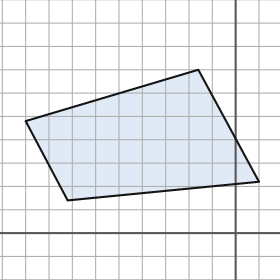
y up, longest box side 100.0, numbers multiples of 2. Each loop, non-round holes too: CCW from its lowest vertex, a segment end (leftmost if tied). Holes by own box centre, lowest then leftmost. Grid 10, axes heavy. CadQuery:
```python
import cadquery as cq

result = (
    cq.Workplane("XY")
    .moveTo(-72.0, 14.0)
    .lineTo(10.0, 22.0)
    .lineTo(-16.0, 70.0)
    .lineTo(-90.0, 48.0)
    .close()
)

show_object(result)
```